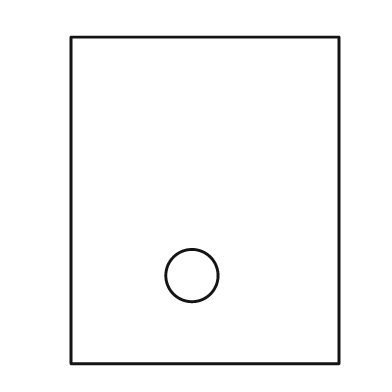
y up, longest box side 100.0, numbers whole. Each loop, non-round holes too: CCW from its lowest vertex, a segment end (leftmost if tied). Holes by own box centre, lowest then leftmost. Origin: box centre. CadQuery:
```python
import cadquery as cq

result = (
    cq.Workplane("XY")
    .moveTo(-41.0, -50.0)
    .lineTo(41.0, -50.0)
    .lineTo(41.0, 50.0)
    .lineTo(-41.0, 50.0)
    .close()
    .moveTo(-4.0, -23.0)
    .circle(8.0)
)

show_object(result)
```